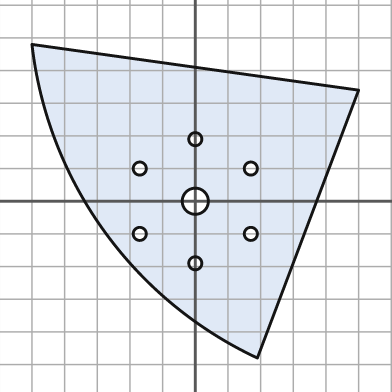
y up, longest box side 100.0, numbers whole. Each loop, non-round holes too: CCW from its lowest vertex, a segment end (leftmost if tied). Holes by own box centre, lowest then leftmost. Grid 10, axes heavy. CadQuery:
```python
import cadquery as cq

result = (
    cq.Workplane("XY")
    .moveTo(19.0, -48.0)
    .lineTo(50.0, 34.0)
    .lineTo(-50.0, 48.0)
    .threePointArc((-28.0, -9.0), (19.0, -48.0))
    .close()
    .moveTo(0.0, -19.0)
    .circle(2.0)
    .moveTo(-17.0, -10.0)
    .circle(2.0)
    .moveTo(17.0, -10.0)
    .circle(2.0)
    .moveTo(0.0, 0.0)
    .circle(4.0)
    .moveTo(-17.0, 10.0)
    .circle(2.0)
    .moveTo(17.0, 10.0)
    .circle(2.0)
    .moveTo(0.0, 19.0)
    .circle(2.0)
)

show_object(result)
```